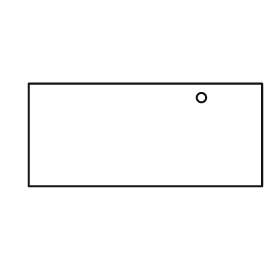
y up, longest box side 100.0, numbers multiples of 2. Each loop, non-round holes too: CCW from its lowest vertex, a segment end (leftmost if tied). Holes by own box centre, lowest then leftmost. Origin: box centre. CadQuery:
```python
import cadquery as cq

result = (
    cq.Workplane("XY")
    .moveTo(-50.0, -22.0)
    .lineTo(50.0, -22.0)
    .lineTo(50.0, 22.0)
    .lineTo(-50.0, 22.0)
    .close()
    .moveTo(24.0, 16.0)
    .circle(2.0)
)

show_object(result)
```